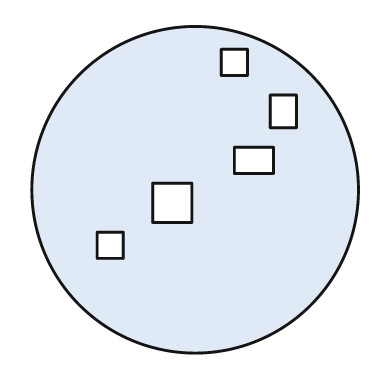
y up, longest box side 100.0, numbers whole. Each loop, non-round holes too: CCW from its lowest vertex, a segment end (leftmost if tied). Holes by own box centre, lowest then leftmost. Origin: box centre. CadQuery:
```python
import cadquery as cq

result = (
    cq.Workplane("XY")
    .moveTo(0.0, 0.0)
    .circle(50.0)
    .moveTo(-30.0, -21.0)
    .lineTo(-22.0, -21.0)
    .lineTo(-22.0, -13.0)
    .lineTo(-30.0, -13.0)
    .close()
    .moveTo(-13.0, -10.0)
    .lineTo(-1.0, -10.0)
    .lineTo(-1.0, 2.0)
    .lineTo(-13.0, 2.0)
    .close()
    .moveTo(12.0, 5.0)
    .lineTo(24.0, 5.0)
    .lineTo(24.0, 13.0)
    .lineTo(12.0, 13.0)
    .close()
    .moveTo(23.0, 19.0)
    .lineTo(31.0, 19.0)
    .lineTo(31.0, 29.0)
    .lineTo(23.0, 29.0)
    .close()
    .moveTo(8.0, 35.0)
    .lineTo(16.0, 35.0)
    .lineTo(16.0, 43.0)
    .lineTo(8.0, 43.0)
    .close()
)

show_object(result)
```